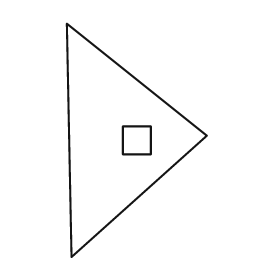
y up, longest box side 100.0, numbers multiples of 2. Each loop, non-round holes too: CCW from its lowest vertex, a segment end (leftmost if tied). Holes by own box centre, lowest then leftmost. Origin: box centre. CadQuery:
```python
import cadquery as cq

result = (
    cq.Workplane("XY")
    .moveTo(-28.0, -50.0)
    .lineTo(30.0, 2.0)
    .lineTo(-30.0, 50.0)
    .close()
    .moveTo(-6.0, -6.0)
    .lineTo(6.0, -6.0)
    .lineTo(6.0, 6.0)
    .lineTo(-6.0, 6.0)
    .close()
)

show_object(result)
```